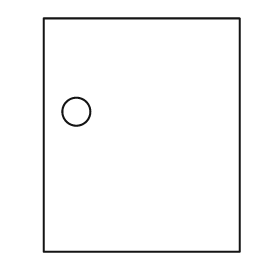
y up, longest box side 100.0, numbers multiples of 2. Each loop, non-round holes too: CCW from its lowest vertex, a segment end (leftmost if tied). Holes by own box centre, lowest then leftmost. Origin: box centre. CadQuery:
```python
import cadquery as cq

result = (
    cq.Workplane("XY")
    .moveTo(-42.0, -50.0)
    .lineTo(42.0, -50.0)
    .lineTo(42.0, 50.0)
    .lineTo(-42.0, 50.0)
    .close()
    .moveTo(-28.0, 10.0)
    .circle(6.0)
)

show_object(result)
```